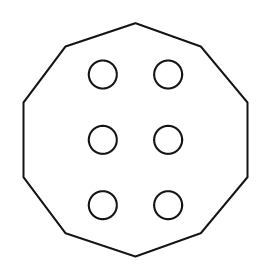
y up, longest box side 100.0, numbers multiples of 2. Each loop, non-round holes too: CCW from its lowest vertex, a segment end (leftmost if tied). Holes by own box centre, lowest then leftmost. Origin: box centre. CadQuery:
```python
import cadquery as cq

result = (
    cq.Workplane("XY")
    .moveTo(0.0, -50.0)
    .lineTo(28.0, -40.0)
    .lineTo(48.0, -16.0)
    .lineTo(48.0, 16.0)
    .lineTo(28.0, 40.0)
    .lineTo(0.0, 50.0)
    .lineTo(-30.0, 40.0)
    .lineTo(-48.0, 16.0)
    .lineTo(-48.0, -16.0)
    .lineTo(-30.0, -40.0)
    .close()
    .moveTo(-14.0, -28.0)
    .circle(6.0)
    .moveTo(14.0, -28.0)
    .circle(6.0)
    .moveTo(-14.0, 0.0)
    .circle(6.0)
    .moveTo(14.0, 0.0)
    .circle(6.0)
    .moveTo(-14.0, 28.0)
    .circle(6.0)
    .moveTo(14.0, 28.0)
    .circle(6.0)
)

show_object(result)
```